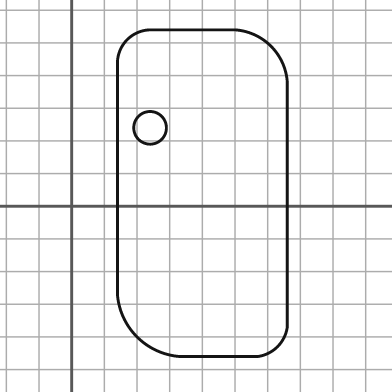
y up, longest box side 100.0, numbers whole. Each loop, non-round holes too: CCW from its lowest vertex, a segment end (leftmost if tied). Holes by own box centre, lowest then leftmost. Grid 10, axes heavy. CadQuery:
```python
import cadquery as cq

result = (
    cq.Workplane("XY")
    .moveTo(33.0, -46.0)
    .lineTo(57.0, -46.0)
    .threePointArc((63.0, -43.0), (66.0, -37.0))
    .lineTo(66.0, 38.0)
    .threePointArc((61.0, 49.0), (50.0, 54.0))
    .lineTo(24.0, 54.0)
    .threePointArc((17.0, 51.0), (14.0, 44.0))
    .lineTo(14.0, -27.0)
    .threePointArc((20.0, -40.0), (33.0, -46.0))
    .close()
    .moveTo(24.0, 24.0)
    .circle(5.0)
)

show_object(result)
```